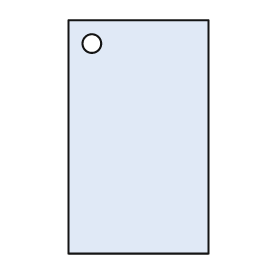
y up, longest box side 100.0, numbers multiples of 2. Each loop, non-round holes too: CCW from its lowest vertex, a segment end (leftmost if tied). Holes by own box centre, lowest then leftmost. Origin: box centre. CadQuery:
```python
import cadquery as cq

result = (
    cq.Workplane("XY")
    .moveTo(-30.0, -50.0)
    .lineTo(30.0, -50.0)
    .lineTo(30.0, 50.0)
    .lineTo(-30.0, 50.0)
    .close()
    .moveTo(-20.0, 40.0)
    .circle(4.0)
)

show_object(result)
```